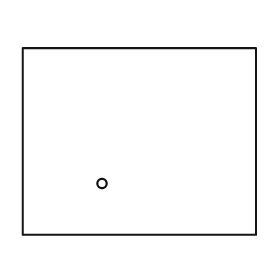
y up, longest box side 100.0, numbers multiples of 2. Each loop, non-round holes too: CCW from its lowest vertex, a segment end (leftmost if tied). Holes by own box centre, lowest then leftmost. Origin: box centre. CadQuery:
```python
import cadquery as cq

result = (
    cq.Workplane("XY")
    .moveTo(-50.0, -40.0)
    .lineTo(50.0, -40.0)
    .lineTo(50.0, 40.0)
    .lineTo(-50.0, 40.0)
    .close()
    .moveTo(-16.0, -18.0)
    .circle(2.0)
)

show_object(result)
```